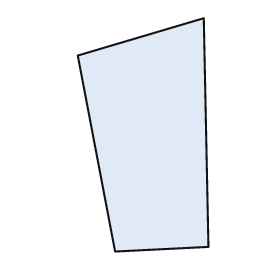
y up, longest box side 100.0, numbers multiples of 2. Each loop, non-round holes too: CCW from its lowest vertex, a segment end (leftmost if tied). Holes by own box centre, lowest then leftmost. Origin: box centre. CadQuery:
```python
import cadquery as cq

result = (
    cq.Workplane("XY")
    .moveTo(-12.0, -50.0)
    .lineTo(28.0, -48.0)
    .lineTo(26.0, 50.0)
    .lineTo(-28.0, 34.0)
    .close()
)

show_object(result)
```